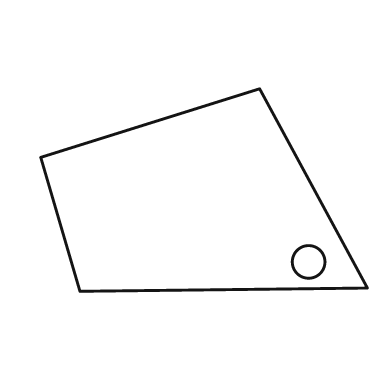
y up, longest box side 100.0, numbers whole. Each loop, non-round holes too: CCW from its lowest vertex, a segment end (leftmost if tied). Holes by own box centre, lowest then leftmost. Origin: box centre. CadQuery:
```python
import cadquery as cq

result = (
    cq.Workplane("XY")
    .moveTo(-38.0, -31.0)
    .lineTo(50.0, -30.0)
    .lineTo(17.0, 31.0)
    .lineTo(-50.0, 10.0)
    .close()
    .moveTo(32.0, -22.0)
    .circle(5.0)
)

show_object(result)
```